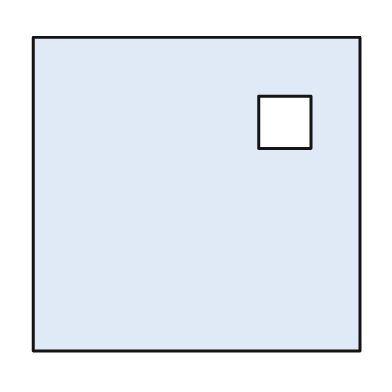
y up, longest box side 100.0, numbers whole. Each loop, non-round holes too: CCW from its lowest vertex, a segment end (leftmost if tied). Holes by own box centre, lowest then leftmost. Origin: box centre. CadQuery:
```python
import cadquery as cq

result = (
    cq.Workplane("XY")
    .moveTo(-50.0, -48.0)
    .lineTo(50.0, -48.0)
    .lineTo(50.0, 48.0)
    .lineTo(-50.0, 48.0)
    .close()
    .moveTo(19.0, 14.0)
    .lineTo(35.0, 14.0)
    .lineTo(35.0, 30.0)
    .lineTo(19.0, 30.0)
    .close()
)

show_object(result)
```